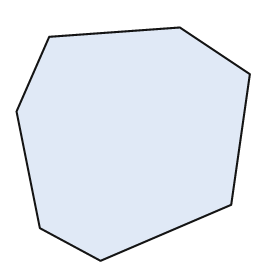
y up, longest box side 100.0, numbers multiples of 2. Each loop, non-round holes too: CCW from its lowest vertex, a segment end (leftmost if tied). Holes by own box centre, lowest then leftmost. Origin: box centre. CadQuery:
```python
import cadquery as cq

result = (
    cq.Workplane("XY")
    .moveTo(-14.0, -50.0)
    .lineTo(42.0, -26.0)
    .lineTo(50.0, 30.0)
    .lineTo(20.0, 50.0)
    .lineTo(-36.0, 46.0)
    .lineTo(-50.0, 14.0)
    .lineTo(-40.0, -36.0)
    .close()
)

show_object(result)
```